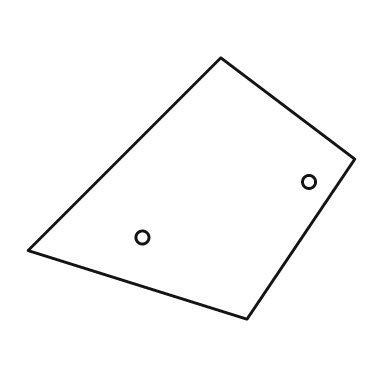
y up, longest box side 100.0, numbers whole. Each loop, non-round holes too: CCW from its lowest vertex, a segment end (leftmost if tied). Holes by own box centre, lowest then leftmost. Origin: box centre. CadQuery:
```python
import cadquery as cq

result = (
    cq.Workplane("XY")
    .moveTo(17.0, -40.0)
    .lineTo(50.0, 9.0)
    .lineTo(9.0, 40.0)
    .lineTo(-50.0, -19.0)
    .close()
    .moveTo(-15.0, -15.0)
    .circle(2.0)
    .moveTo(36.0, 2.0)
    .circle(2.0)
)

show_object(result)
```